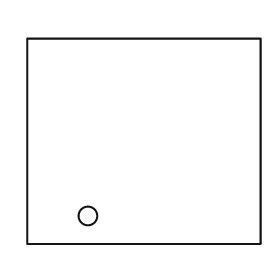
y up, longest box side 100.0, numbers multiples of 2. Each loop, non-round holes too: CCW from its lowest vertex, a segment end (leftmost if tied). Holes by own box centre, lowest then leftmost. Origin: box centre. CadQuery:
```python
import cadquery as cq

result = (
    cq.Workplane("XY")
    .moveTo(-50.0, -44.0)
    .lineTo(50.0, -44.0)
    .lineTo(50.0, 44.0)
    .lineTo(-50.0, 44.0)
    .close()
    .moveTo(-24.0, -32.0)
    .circle(4.0)
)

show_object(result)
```